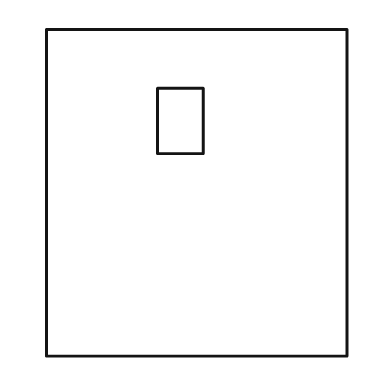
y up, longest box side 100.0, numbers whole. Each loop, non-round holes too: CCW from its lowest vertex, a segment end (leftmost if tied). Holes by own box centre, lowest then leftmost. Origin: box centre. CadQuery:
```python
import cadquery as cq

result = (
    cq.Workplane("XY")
    .moveTo(-46.0, -50.0)
    .lineTo(46.0, -50.0)
    .lineTo(46.0, 50.0)
    .lineTo(-46.0, 50.0)
    .close()
    .moveTo(-12.0, 12.0)
    .lineTo(2.0, 12.0)
    .lineTo(2.0, 32.0)
    .lineTo(-12.0, 32.0)
    .close()
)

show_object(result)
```